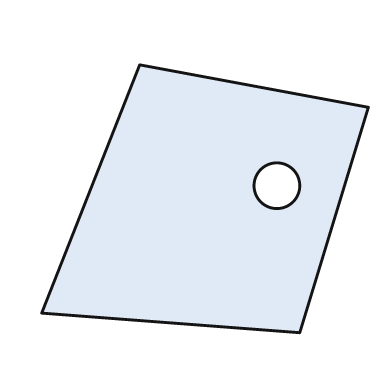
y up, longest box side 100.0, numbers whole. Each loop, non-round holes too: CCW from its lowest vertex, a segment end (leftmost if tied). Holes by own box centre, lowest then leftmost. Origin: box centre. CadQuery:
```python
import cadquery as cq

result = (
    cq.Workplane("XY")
    .moveTo(29.0, -41.0)
    .lineTo(50.0, 28.0)
    .lineTo(-20.0, 41.0)
    .lineTo(-50.0, -35.0)
    .close()
    .moveTo(22.0, 4.0)
    .circle(7.0)
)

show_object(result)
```